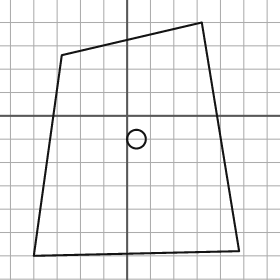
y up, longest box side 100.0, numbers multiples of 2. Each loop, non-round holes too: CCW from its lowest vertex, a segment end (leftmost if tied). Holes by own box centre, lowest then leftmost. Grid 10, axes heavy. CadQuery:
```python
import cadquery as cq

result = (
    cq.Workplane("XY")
    .moveTo(-40.0, -60.0)
    .lineTo(48.0, -58.0)
    .lineTo(32.0, 40.0)
    .lineTo(-28.0, 26.0)
    .close()
    .moveTo(4.0, -10.0)
    .circle(4.0)
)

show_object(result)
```